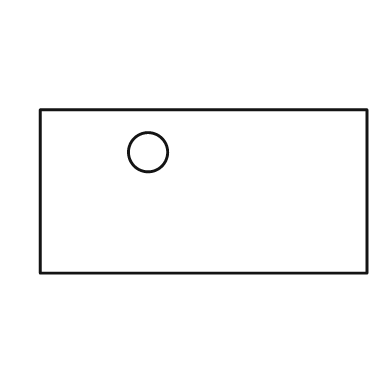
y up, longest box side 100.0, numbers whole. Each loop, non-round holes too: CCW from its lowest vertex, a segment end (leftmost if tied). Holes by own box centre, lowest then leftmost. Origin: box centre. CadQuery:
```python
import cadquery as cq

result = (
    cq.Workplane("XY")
    .moveTo(-50.0, -25.0)
    .lineTo(50.0, -25.0)
    .lineTo(50.0, 25.0)
    .lineTo(-50.0, 25.0)
    .close()
    .moveTo(-17.0, 12.0)
    .circle(6.0)
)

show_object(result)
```